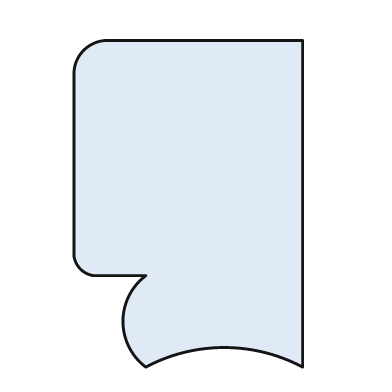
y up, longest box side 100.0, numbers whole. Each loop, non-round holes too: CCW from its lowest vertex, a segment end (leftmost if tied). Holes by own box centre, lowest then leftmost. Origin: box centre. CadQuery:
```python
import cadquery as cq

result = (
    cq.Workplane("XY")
    .moveTo(-13.0, -50.0)
    .threePointArc((11.0, -44.0), (35.0, -50.0))
    .lineTo(35.0, 50.0)
    .lineTo(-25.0, 50.0)
    .threePointArc((-32.0, 47.0), (-35.0, 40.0))
    .lineTo(-35.0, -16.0)
    .threePointArc((-33.0, -20.0), (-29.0, -22.0))
    .lineTo(-13.0, -22.0)
    .threePointArc((-20.0, -36.0), (-13.0, -50.0))
    .close()
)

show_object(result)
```